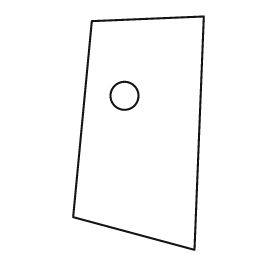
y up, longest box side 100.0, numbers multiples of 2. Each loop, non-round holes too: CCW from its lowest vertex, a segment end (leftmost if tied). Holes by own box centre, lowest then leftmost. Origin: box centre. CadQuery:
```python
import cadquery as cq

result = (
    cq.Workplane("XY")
    .moveTo(24.0, -50.0)
    .lineTo(28.0, 50.0)
    .lineTo(-20.0, 48.0)
    .lineTo(-28.0, -36.0)
    .close()
    .moveTo(-6.0, 16.0)
    .circle(6.0)
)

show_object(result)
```